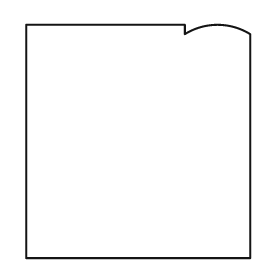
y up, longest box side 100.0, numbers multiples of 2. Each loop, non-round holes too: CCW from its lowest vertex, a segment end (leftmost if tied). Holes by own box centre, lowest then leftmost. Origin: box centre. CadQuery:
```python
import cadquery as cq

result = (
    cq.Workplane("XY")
    .moveTo(-48.0, -50.0)
    .lineTo(48.0, -50.0)
    .lineTo(48.0, 46.0)
    .threePointArc((34.0, 50.0), (20.0, 46.0))
    .lineTo(20.0, 50.0)
    .lineTo(-48.0, 50.0)
    .close()
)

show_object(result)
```